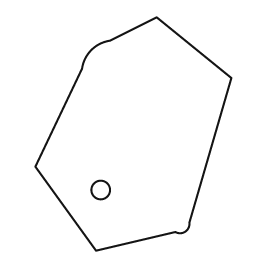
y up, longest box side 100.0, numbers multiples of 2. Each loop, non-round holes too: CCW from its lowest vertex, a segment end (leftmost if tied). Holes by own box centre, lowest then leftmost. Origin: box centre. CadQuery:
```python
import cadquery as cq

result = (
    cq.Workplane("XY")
    .moveTo(-16.0, -50.0)
    .lineTo(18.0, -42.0)
    .threePointArc((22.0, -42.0), (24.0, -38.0))
    .lineTo(42.0, 24.0)
    .lineTo(10.0, 50.0)
    .lineTo(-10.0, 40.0)
    .threePointArc((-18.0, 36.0), (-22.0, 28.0))
    .lineTo(-42.0, -14.0)
    .close()
    .moveTo(-14.0, -24.0)
    .circle(4.0)
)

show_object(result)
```